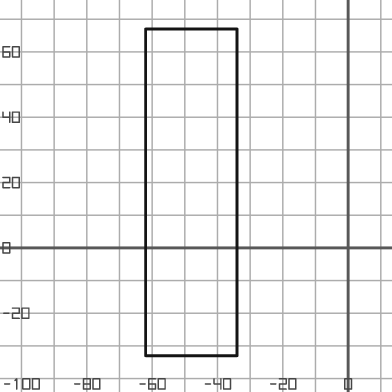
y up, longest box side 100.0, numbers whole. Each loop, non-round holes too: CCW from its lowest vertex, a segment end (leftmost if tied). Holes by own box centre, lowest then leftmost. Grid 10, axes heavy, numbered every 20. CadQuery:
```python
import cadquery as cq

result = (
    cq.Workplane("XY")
    .moveTo(-62.0, -33.0)
    .lineTo(-34.0, -33.0)
    .lineTo(-34.0, 67.0)
    .lineTo(-62.0, 67.0)
    .close()
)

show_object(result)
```